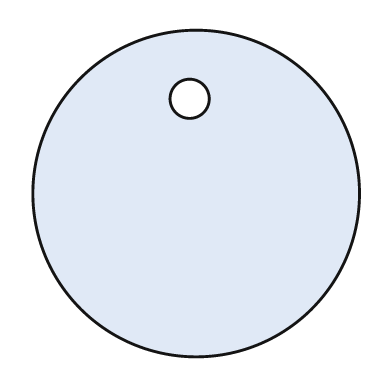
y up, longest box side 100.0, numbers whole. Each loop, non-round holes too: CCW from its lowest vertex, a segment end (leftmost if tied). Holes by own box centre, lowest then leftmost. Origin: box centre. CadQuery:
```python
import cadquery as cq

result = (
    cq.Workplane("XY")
    .moveTo(0.0, 0.0)
    .circle(50.0)
    .moveTo(-2.0, 29.0)
    .circle(6.0)
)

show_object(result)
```